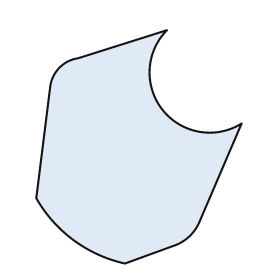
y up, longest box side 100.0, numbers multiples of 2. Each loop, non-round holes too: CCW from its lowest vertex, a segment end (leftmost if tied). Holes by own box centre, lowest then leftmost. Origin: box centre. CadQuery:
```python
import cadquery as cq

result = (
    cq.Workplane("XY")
    .moveTo(-6.0, -50.0)
    .lineTo(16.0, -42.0)
    .threePointArc((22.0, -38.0), (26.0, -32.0))
    .lineTo(44.0, 10.0)
    .threePointArc((10.0, 16.0), (12.0, 50.0))
    .lineTo(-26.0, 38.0)
    .threePointArc((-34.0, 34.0), (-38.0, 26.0))
    .lineTo(-44.0, -22.0)
    .threePointArc((-28.0, -40.0), (-6.0, -50.0))
    .close()
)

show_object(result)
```